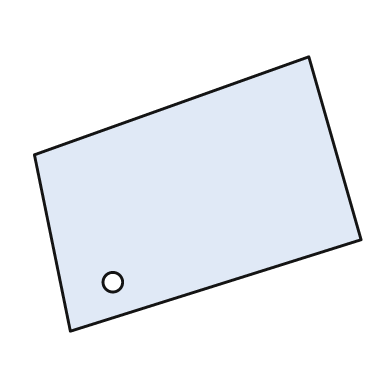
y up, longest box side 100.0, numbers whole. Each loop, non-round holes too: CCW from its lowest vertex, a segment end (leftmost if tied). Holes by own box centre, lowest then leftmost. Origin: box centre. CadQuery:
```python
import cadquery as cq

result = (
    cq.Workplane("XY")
    .moveTo(-39.0, -42.0)
    .lineTo(50.0, -14.0)
    .lineTo(34.0, 42.0)
    .lineTo(-50.0, 12.0)
    .close()
    .moveTo(-26.0, -27.0)
    .circle(3.0)
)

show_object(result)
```